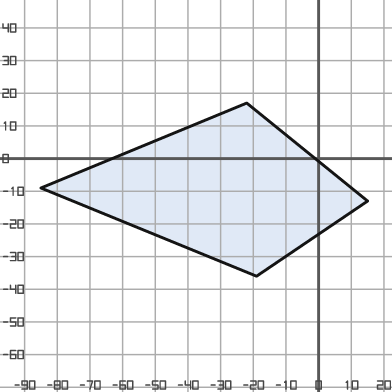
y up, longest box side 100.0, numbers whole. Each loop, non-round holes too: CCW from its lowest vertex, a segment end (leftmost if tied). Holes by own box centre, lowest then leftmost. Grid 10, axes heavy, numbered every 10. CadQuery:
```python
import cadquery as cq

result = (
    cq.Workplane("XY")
    .moveTo(-19.0, -36.0)
    .lineTo(15.0, -13.0)
    .lineTo(-22.0, 17.0)
    .lineTo(-85.0, -9.0)
    .close()
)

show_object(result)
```